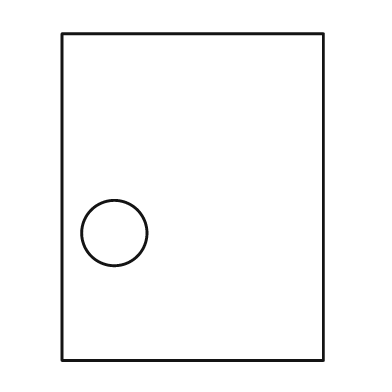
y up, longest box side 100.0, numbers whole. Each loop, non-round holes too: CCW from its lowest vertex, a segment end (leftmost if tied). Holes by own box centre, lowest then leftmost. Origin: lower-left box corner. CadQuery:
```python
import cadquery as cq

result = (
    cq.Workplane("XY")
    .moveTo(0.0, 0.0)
    .lineTo(80.0, 0.0)
    .lineTo(80.0, 100.0)
    .lineTo(0.0, 100.0)
    .close()
    .moveTo(16.0, 39.0)
    .circle(10.0)
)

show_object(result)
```